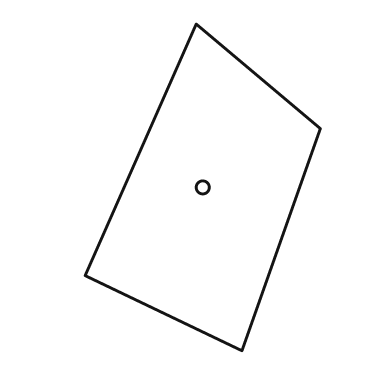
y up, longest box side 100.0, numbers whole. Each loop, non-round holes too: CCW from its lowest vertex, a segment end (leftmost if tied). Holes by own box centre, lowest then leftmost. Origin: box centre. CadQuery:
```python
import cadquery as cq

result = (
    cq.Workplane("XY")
    .moveTo(12.0, -50.0)
    .lineTo(36.0, 18.0)
    .lineTo(-2.0, 50.0)
    .lineTo(-36.0, -27.0)
    .close()
    .moveTo(0.0, 0.0)
    .circle(2.0)
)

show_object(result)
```